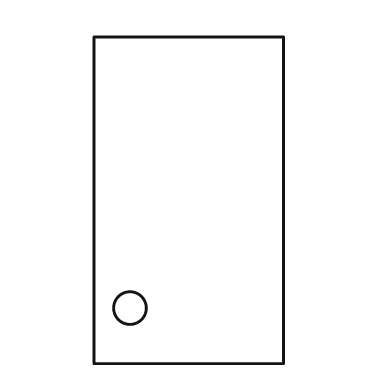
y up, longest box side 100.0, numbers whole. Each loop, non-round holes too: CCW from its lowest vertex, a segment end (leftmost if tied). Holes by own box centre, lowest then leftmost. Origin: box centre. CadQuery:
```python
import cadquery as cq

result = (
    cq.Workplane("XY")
    .moveTo(-29.0, -50.0)
    .lineTo(29.0, -50.0)
    .lineTo(29.0, 50.0)
    .lineTo(-29.0, 50.0)
    .close()
    .moveTo(-18.0, -33.0)
    .circle(5.0)
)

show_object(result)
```